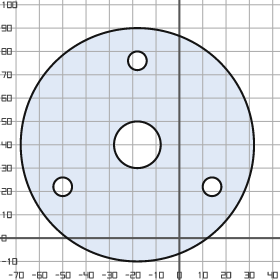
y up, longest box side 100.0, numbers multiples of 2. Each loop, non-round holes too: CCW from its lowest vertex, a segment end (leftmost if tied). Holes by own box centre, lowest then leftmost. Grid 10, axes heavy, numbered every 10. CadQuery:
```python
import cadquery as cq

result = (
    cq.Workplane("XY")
    .moveTo(-18.0, 40.0)
    .circle(50.0)
    .moveTo(-50.0, 22.0)
    .circle(4.0)
    .moveTo(14.0, 22.0)
    .circle(4.0)
    .moveTo(-18.0, 40.0)
    .circle(10.0)
    .moveTo(-18.0, 76.0)
    .circle(4.0)
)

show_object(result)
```